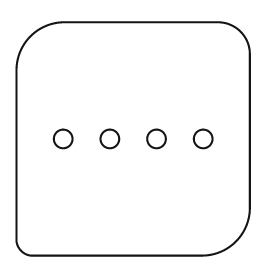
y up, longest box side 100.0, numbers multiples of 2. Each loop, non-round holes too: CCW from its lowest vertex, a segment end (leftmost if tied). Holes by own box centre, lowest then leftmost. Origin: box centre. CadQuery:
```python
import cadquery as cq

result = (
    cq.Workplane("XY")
    .moveTo(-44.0, -50.0)
    .lineTo(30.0, -50.0)
    .threePointArc((44.0, -44.0), (50.0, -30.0))
    .lineTo(50.0, 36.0)
    .threePointArc((46.0, 46.0), (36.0, 50.0))
    .lineTo(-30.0, 50.0)
    .threePointArc((-44.0, 44.0), (-50.0, 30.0))
    .lineTo(-50.0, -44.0)
    .threePointArc((-48.0, -48.0), (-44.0, -50.0))
    .close()
    .moveTo(-30.0, 0.0)
    .circle(4.0)
    .moveTo(-10.0, 0.0)
    .circle(4.0)
    .moveTo(10.0, 0.0)
    .circle(4.0)
    .moveTo(30.0, 0.0)
    .circle(4.0)
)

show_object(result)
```